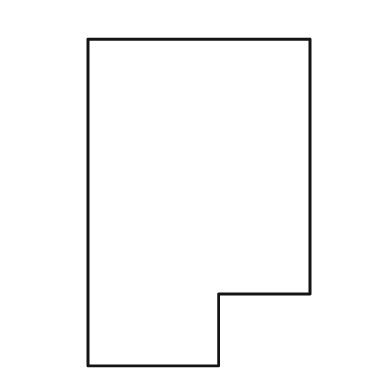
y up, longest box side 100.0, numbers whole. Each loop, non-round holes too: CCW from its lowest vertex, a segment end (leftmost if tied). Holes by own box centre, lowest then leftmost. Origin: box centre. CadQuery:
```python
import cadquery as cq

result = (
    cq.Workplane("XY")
    .moveTo(-34.0, -50.0)
    .lineTo(6.0, -50.0)
    .lineTo(6.0, -28.0)
    .lineTo(34.0, -28.0)
    .lineTo(34.0, 50.0)
    .lineTo(-34.0, 50.0)
    .close()
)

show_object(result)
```